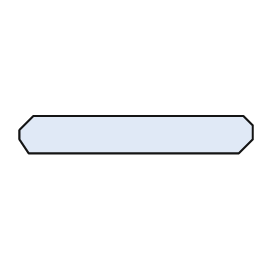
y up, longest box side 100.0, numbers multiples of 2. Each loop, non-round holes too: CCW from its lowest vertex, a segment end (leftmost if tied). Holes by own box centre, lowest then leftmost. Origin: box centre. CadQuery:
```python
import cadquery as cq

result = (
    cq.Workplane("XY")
    .moveTo(-46.0, -8.0)
    .lineTo(44.0, -8.0)
    .lineTo(50.0, -2.0)
    .lineTo(50.0, 4.0)
    .lineTo(46.0, 8.0)
    .lineTo(-44.0, 8.0)
    .lineTo(-50.0, 2.0)
    .lineTo(-50.0, -2.0)
    .close()
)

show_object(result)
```